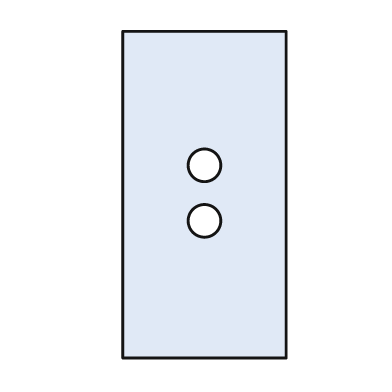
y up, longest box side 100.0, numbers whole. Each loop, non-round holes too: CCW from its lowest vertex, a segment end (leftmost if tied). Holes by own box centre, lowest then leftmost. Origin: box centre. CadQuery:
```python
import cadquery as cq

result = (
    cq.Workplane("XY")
    .moveTo(-25.0, -50.0)
    .lineTo(25.0, -50.0)
    .lineTo(25.0, 50.0)
    .lineTo(-25.0, 50.0)
    .close()
    .moveTo(0.0, -8.0)
    .circle(5.0)
    .moveTo(0.0, 9.0)
    .circle(5.0)
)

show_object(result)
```